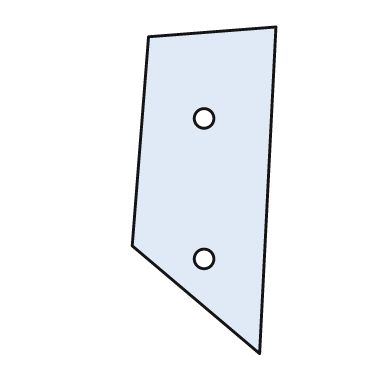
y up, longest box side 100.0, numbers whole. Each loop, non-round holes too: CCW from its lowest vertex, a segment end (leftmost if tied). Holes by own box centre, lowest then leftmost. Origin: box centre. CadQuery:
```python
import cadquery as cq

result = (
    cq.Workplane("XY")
    .moveTo(17.0, -50.0)
    .lineTo(22.0, 50.0)
    .lineTo(-17.0, 47.0)
    .lineTo(-22.0, -17.0)
    .close()
    .moveTo(0.0, -21.0)
    .circle(3.0)
    .moveTo(0.0, 22.0)
    .circle(3.0)
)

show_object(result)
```